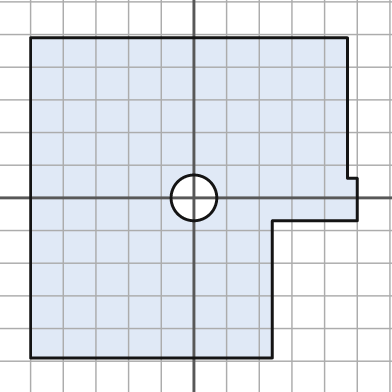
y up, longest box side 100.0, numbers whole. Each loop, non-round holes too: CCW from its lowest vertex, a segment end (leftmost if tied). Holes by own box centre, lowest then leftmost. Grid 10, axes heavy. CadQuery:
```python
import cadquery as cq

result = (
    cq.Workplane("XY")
    .moveTo(-50.0, -49.0)
    .lineTo(24.0, -49.0)
    .lineTo(24.0, -7.0)
    .lineTo(50.0, -7.0)
    .lineTo(50.0, 6.0)
    .lineTo(47.0, 6.0)
    .lineTo(47.0, 49.0)
    .lineTo(-50.0, 49.0)
    .close()
    .moveTo(0.0, 0.0)
    .circle(7.0)
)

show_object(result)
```